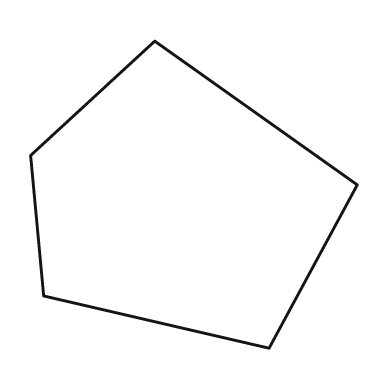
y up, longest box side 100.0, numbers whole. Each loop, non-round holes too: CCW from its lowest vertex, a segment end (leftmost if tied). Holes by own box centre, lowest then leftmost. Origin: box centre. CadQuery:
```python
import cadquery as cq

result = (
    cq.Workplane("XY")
    .moveTo(23.0, -47.0)
    .lineTo(50.0, 3.0)
    .lineTo(-12.0, 47.0)
    .lineTo(-50.0, 12.0)
    .lineTo(-46.0, -31.0)
    .close()
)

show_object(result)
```